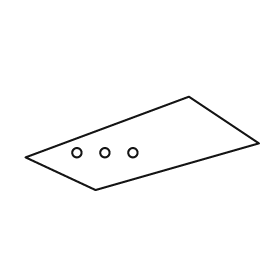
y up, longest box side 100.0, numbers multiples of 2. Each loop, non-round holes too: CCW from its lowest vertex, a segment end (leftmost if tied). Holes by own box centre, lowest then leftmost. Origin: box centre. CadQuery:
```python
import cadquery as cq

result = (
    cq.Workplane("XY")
    .moveTo(-20.0, -20.0)
    .lineTo(50.0, 0.0)
    .lineTo(20.0, 20.0)
    .lineTo(-50.0, -6.0)
    .close()
    .moveTo(-28.0, -4.0)
    .circle(2.0)
    .moveTo(-16.0, -4.0)
    .circle(2.0)
    .moveTo(-4.0, -4.0)
    .circle(2.0)
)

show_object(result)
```